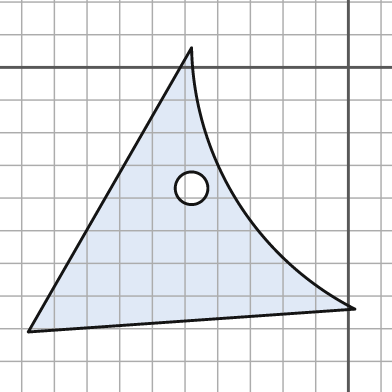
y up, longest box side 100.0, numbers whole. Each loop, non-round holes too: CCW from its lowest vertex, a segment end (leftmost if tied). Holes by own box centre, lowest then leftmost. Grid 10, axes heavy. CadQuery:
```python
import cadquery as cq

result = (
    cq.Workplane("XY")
    .moveTo(-98.0, -81.0)
    .lineTo(2.0, -74.0)
    .threePointArc((-34.0, -41.0), (-48.0, 6.0))
    .close()
    .moveTo(-48.0, -37.0)
    .circle(5.0)
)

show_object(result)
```